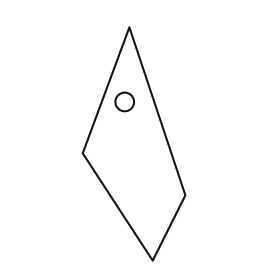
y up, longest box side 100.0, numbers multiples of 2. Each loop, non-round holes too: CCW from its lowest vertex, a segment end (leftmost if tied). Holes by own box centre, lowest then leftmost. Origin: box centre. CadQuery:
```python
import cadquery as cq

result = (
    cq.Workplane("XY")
    .moveTo(8.0, -50.0)
    .lineTo(22.0, -22.0)
    .lineTo(-2.0, 50.0)
    .lineTo(-22.0, -4.0)
    .close()
    .moveTo(-4.0, 18.0)
    .circle(4.0)
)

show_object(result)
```